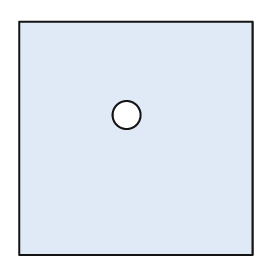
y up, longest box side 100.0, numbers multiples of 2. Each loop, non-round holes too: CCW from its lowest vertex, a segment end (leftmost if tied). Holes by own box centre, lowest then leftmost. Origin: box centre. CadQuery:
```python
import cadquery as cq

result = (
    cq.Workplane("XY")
    .moveTo(-50.0, -50.0)
    .lineTo(50.0, -50.0)
    .lineTo(50.0, 50.0)
    .lineTo(-50.0, 50.0)
    .close()
    .moveTo(-4.0, 10.0)
    .circle(6.0)
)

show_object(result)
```